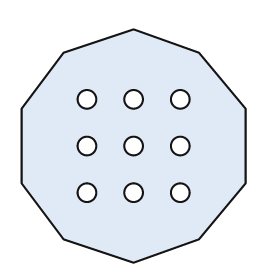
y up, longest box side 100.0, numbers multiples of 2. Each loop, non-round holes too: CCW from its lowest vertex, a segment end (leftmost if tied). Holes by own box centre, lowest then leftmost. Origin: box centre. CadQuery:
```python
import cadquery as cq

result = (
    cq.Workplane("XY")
    .moveTo(0.0, -50.0)
    .lineTo(28.0, -40.0)
    .lineTo(48.0, -16.0)
    .lineTo(48.0, 16.0)
    .lineTo(28.0, 40.0)
    .lineTo(0.0, 50.0)
    .lineTo(-30.0, 40.0)
    .lineTo(-48.0, 16.0)
    .lineTo(-48.0, -16.0)
    .lineTo(-30.0, -40.0)
    .close()
    .moveTo(-20.0, -20.0)
    .circle(4.0)
    .moveTo(0.0, -20.0)
    .circle(4.0)
    .moveTo(20.0, -20.0)
    .circle(4.0)
    .moveTo(-20.0, 0.0)
    .circle(4.0)
    .moveTo(0.0, 0.0)
    .circle(4.0)
    .moveTo(20.0, 0.0)
    .circle(4.0)
    .moveTo(-20.0, 20.0)
    .circle(4.0)
    .moveTo(0.0, 20.0)
    .circle(4.0)
    .moveTo(20.0, 20.0)
    .circle(4.0)
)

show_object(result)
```